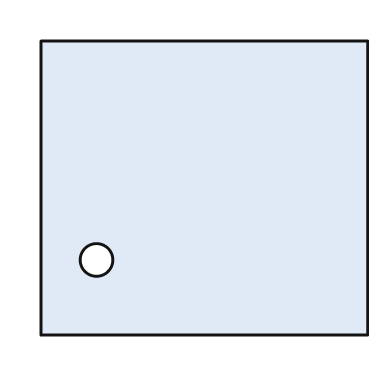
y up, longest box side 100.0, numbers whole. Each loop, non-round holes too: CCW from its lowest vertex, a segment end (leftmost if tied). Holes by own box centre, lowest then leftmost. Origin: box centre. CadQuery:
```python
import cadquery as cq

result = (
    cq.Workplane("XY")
    .moveTo(-50.0, -45.0)
    .lineTo(50.0, -45.0)
    .lineTo(50.0, 45.0)
    .lineTo(-50.0, 45.0)
    .close()
    .moveTo(-33.0, -22.0)
    .circle(5.0)
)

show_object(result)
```